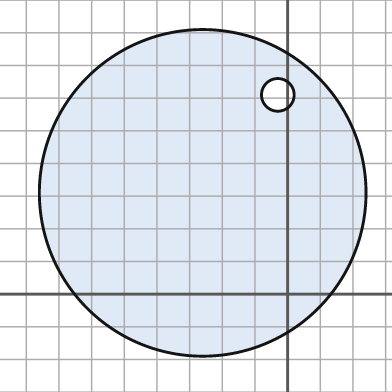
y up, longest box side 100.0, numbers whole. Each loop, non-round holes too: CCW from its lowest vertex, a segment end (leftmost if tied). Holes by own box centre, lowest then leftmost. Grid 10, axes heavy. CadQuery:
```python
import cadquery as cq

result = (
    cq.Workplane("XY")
    .moveTo(-26.0, 31.0)
    .circle(50.0)
    .moveTo(-3.0, 61.0)
    .circle(5.0)
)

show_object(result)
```